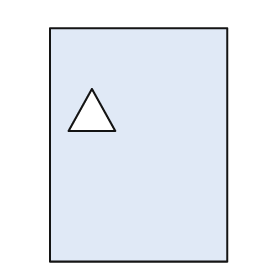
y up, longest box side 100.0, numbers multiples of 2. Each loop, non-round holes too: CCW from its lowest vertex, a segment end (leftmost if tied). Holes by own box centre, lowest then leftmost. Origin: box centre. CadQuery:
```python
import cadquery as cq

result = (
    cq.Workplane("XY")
    .moveTo(-38.0, -50.0)
    .lineTo(38.0, -50.0)
    .lineTo(38.0, 50.0)
    .lineTo(-38.0, 50.0)
    .close()
    .moveTo(-30.0, 6.0)
    .lineTo(-10.0, 6.0)
    .lineTo(-20.0, 24.0)
    .close()
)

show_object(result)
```